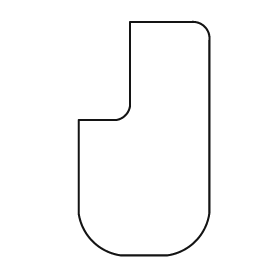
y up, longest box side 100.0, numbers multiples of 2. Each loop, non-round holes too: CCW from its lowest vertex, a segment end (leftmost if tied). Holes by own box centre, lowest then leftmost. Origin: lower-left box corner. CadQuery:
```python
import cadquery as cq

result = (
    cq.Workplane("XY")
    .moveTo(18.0, 0.0)
    .lineTo(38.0, 0.0)
    .threePointArc((50.0, 6.0), (56.0, 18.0))
    .lineTo(56.0, 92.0)
    .threePointArc((54.0, 98.0), (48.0, 100.0))
    .lineTo(22.0, 100.0)
    .lineTo(22.0, 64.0)
    .threePointArc((20.0, 60.0), (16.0, 58.0))
    .lineTo(0.0, 58.0)
    .lineTo(0.0, 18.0)
    .threePointArc((6.0, 6.0), (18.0, 0.0))
    .close()
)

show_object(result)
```